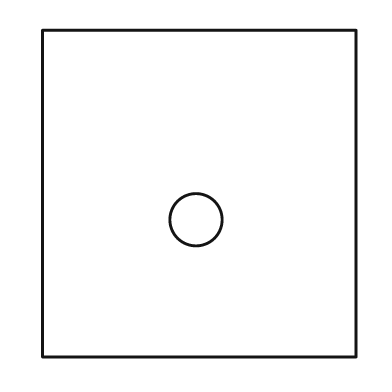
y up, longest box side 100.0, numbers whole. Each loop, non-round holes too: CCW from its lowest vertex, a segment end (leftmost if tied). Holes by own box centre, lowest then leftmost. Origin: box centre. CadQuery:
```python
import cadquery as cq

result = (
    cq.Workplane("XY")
    .moveTo(-48.0, -50.0)
    .lineTo(48.0, -50.0)
    .lineTo(48.0, 50.0)
    .lineTo(-48.0, 50.0)
    .close()
    .moveTo(-1.0, -8.0)
    .circle(8.0)
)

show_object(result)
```